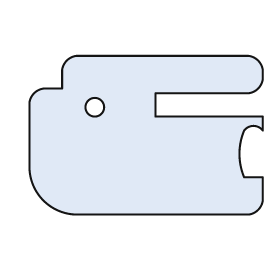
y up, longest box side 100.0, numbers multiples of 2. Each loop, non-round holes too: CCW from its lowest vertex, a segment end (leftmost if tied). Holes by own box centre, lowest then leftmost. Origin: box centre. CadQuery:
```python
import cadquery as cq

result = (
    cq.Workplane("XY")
    .moveTo(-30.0, -34.0)
    .lineTo(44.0, -34.0)
    .threePointArc((48.0, -32.0), (50.0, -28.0))
    .lineTo(50.0, -18.0)
    .lineTo(42.0, -18.0)
    .threePointArc((40.0, -8.0), (42.0, 2.0))
    .threePointArc((46.0, 4.0), (50.0, 2.0))
    .lineTo(50.0, 8.0)
    .lineTo(4.0, 8.0)
    .lineTo(4.0, 18.0)
    .lineTo(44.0, 18.0)
    .threePointArc((48.0, 20.0), (50.0, 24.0))
    .lineTo(50.0, 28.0)
    .threePointArc((48.0, 32.0), (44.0, 34.0))
    .lineTo(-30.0, 34.0)
    .threePointArc((-34.0, 32.0), (-36.0, 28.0))
    .lineTo(-36.0, 20.0)
    .lineTo(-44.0, 20.0)
    .threePointArc((-48.0, 18.0), (-50.0, 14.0))
    .lineTo(-50.0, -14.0)
    .threePointArc((-44.0, -28.0), (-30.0, -34.0))
    .close()
    .moveTo(-22.0, 12.0)
    .circle(4.0)
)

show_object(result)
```